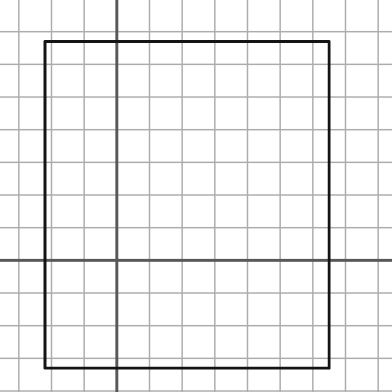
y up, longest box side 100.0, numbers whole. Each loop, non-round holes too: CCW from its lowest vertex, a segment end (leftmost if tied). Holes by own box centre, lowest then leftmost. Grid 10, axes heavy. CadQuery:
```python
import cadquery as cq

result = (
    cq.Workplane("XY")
    .moveTo(-22.0, -33.0)
    .lineTo(65.0, -33.0)
    .lineTo(65.0, 67.0)
    .lineTo(-22.0, 67.0)
    .close()
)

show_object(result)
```